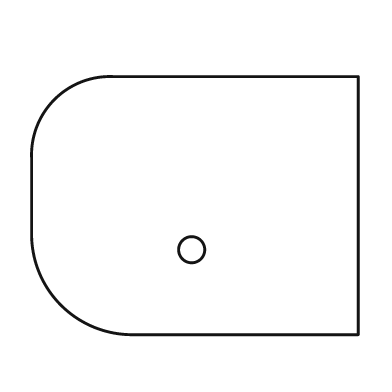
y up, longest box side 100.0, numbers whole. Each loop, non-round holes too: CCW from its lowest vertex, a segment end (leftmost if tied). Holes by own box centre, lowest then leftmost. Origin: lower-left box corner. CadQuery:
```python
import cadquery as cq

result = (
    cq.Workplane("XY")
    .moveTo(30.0, 0.0)
    .lineTo(100.0, 0.0)
    .lineTo(100.0, 79.0)
    .lineTo(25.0, 79.0)
    .threePointArc((7.0, 72.0), (0.0, 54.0))
    .lineTo(0.0, 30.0)
    .threePointArc((9.0, 9.0), (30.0, 0.0))
    .close()
    .moveTo(49.0, 26.0)
    .circle(4.0)
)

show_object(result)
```